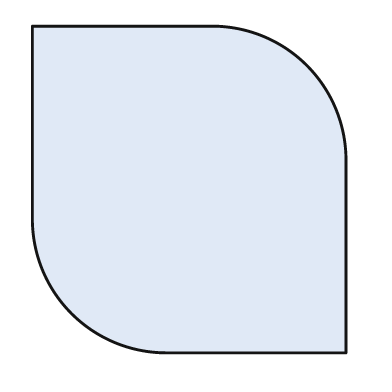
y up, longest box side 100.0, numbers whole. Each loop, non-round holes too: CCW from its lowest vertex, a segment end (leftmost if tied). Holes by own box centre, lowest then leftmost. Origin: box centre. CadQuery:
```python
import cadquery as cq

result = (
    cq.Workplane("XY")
    .moveTo(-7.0, -50.0)
    .lineTo(48.0, -50.0)
    .lineTo(48.0, 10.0)
    .threePointArc((36.0, 38.0), (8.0, 50.0))
    .lineTo(-48.0, 50.0)
    .lineTo(-48.0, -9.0)
    .threePointArc((-36.0, -38.0), (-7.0, -50.0))
    .close()
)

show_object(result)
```